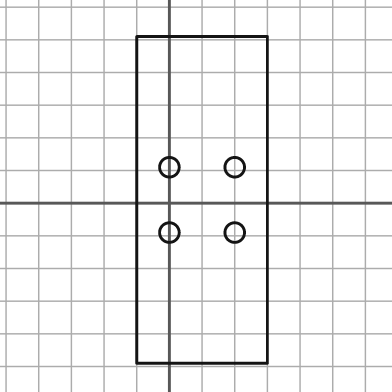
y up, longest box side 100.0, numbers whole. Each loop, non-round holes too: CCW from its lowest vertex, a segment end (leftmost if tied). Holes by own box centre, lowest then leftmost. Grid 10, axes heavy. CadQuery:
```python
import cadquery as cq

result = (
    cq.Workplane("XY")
    .moveTo(-10.0, -49.0)
    .lineTo(30.0, -49.0)
    .lineTo(30.0, 51.0)
    .lineTo(-10.0, 51.0)
    .close()
    .moveTo(0.0, -9.0)
    .circle(3.0)
    .moveTo(20.0, -9.0)
    .circle(3.0)
    .moveTo(0.0, 11.0)
    .circle(3.0)
    .moveTo(20.0, 11.0)
    .circle(3.0)
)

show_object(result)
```